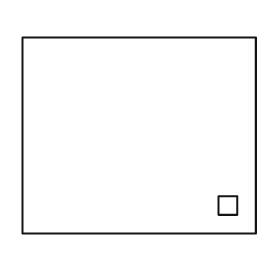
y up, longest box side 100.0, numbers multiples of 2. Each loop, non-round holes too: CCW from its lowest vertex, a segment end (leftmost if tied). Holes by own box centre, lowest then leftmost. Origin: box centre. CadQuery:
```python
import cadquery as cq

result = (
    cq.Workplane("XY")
    .moveTo(-50.0, -42.0)
    .lineTo(50.0, -42.0)
    .lineTo(50.0, 42.0)
    .lineTo(-50.0, 42.0)
    .close()
    .moveTo(34.0, -34.0)
    .lineTo(42.0, -34.0)
    .lineTo(42.0, -26.0)
    .lineTo(34.0, -26.0)
    .close()
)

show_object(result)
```